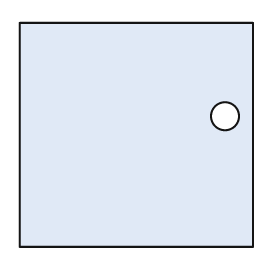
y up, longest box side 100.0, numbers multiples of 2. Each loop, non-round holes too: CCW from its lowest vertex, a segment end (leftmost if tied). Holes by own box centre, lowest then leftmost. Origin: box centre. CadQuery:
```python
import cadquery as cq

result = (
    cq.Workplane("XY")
    .moveTo(-50.0, -48.0)
    .lineTo(50.0, -48.0)
    .lineTo(50.0, 48.0)
    .lineTo(-50.0, 48.0)
    .close()
    .moveTo(38.0, 8.0)
    .circle(6.0)
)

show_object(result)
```